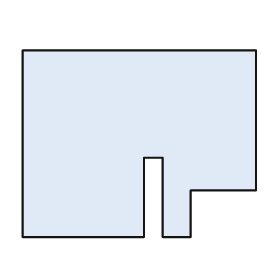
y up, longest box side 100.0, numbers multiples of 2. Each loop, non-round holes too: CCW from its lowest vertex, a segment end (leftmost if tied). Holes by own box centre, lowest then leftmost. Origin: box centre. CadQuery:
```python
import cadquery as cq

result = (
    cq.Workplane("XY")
    .moveTo(-50.0, -40.0)
    .lineTo(2.0, -40.0)
    .lineTo(2.0, -6.0)
    .lineTo(10.0, -6.0)
    .lineTo(10.0, -40.0)
    .lineTo(22.0, -40.0)
    .lineTo(22.0, -20.0)
    .lineTo(50.0, -20.0)
    .lineTo(50.0, 40.0)
    .lineTo(-50.0, 40.0)
    .close()
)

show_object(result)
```